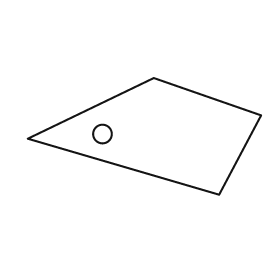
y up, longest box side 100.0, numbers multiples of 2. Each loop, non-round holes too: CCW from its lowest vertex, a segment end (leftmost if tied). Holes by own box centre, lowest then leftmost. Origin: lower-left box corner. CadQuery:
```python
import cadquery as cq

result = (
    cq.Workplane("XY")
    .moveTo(82.0, 0.0)
    .lineTo(100.0, 34.0)
    .lineTo(54.0, 50.0)
    .lineTo(0.0, 24.0)
    .close()
    .moveTo(32.0, 26.0)
    .circle(4.0)
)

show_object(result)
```